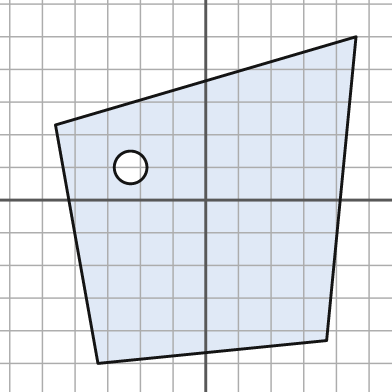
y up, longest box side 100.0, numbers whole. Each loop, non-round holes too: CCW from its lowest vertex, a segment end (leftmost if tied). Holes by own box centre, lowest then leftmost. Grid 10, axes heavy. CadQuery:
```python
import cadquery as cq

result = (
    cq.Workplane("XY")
    .moveTo(-33.0, -50.0)
    .lineTo(37.0, -43.0)
    .lineTo(46.0, 50.0)
    .lineTo(-46.0, 23.0)
    .close()
    .moveTo(-23.0, 10.0)
    .circle(5.0)
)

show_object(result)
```